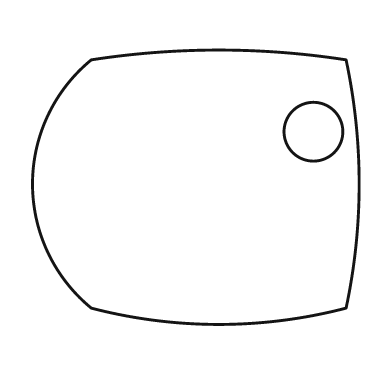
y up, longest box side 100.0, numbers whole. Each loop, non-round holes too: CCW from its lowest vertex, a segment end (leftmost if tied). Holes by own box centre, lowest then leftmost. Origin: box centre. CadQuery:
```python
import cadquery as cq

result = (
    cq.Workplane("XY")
    .moveTo(-32.0, -37.0)
    .threePointArc((7.0, -42.0), (46.0, -37.0))
    .threePointArc((50.0, 1.0), (46.0, 39.0))
    .threePointArc((7.0, 42.0), (-32.0, 39.0))
    .threePointArc((-50.0, 1.0), (-32.0, -37.0))
    .close()
    .moveTo(36.0, 17.0)
    .circle(9.0)
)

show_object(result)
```